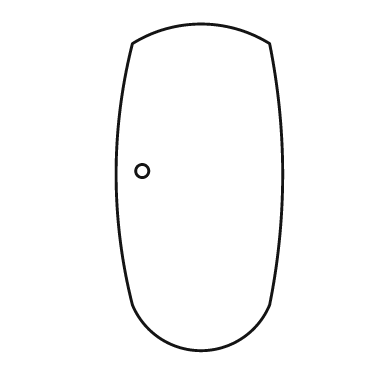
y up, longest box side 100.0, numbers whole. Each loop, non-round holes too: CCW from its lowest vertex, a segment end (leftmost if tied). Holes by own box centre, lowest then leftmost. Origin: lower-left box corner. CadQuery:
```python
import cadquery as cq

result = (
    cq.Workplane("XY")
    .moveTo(5.0, 14.0)
    .threePointArc((26.0, 0.0), (47.0, 14.0))
    .threePointArc((51.0, 54.0), (47.0, 94.0))
    .threePointArc((26.0, 100.0), (5.0, 94.0))
    .threePointArc((0.0, 54.0), (5.0, 14.0))
    .close()
    .moveTo(8.0, 55.0)
    .circle(2.0)
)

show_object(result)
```